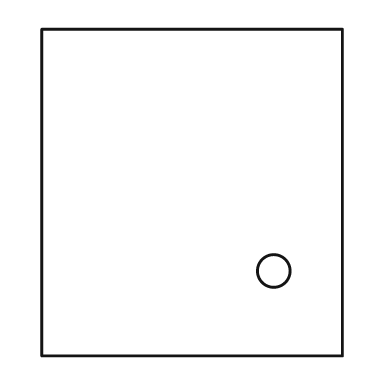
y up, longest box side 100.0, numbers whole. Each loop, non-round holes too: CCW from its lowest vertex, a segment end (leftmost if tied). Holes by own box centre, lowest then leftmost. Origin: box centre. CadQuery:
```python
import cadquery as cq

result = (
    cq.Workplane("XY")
    .moveTo(-46.0, -50.0)
    .lineTo(46.0, -50.0)
    .lineTo(46.0, 50.0)
    .lineTo(-46.0, 50.0)
    .close()
    .moveTo(25.0, -24.0)
    .circle(5.0)
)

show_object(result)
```